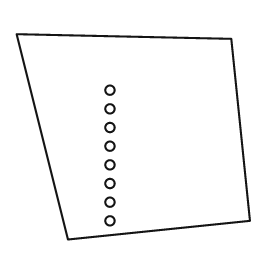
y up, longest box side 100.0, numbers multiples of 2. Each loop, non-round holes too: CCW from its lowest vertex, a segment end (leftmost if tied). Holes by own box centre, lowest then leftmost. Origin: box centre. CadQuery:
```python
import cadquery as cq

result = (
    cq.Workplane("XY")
    .moveTo(-28.0, -44.0)
    .lineTo(50.0, -36.0)
    .lineTo(42.0, 42.0)
    .lineTo(-50.0, 44.0)
    .close()
    .moveTo(-10.0, -36.0)
    .circle(2.0)
    .moveTo(-10.0, -28.0)
    .circle(2.0)
    .moveTo(-10.0, -20.0)
    .circle(2.0)
    .moveTo(-10.0, -12.0)
    .circle(2.0)
    .moveTo(-10.0, -4.0)
    .circle(2.0)
    .moveTo(-10.0, 4.0)
    .circle(2.0)
    .moveTo(-10.0, 12.0)
    .circle(2.0)
    .moveTo(-10.0, 20.0)
    .circle(2.0)
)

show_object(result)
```